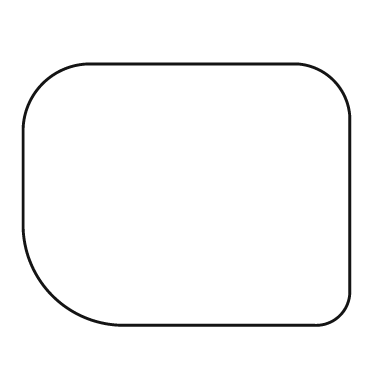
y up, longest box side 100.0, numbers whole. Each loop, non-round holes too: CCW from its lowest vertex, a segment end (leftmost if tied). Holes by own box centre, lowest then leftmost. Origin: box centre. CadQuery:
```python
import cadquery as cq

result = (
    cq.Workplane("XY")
    .moveTo(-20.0, -40.0)
    .lineTo(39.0, -40.0)
    .threePointArc((47.0, -37.0), (50.0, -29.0))
    .lineTo(50.0, 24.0)
    .threePointArc((45.0, 35.0), (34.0, 40.0))
    .lineTo(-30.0, 40.0)
    .threePointArc((-44.0, 34.0), (-50.0, 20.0))
    .lineTo(-50.0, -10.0)
    .threePointArc((-41.0, -31.0), (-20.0, -40.0))
    .close()
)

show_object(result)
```